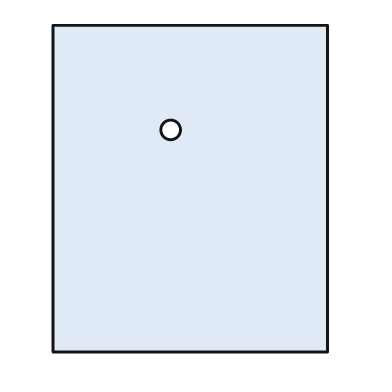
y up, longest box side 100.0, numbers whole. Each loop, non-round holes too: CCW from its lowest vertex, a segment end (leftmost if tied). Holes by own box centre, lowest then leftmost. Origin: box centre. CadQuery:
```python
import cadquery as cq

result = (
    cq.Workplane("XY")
    .moveTo(-42.0, -50.0)
    .lineTo(42.0, -50.0)
    .lineTo(42.0, 50.0)
    .lineTo(-42.0, 50.0)
    .close()
    .moveTo(-6.0, 18.0)
    .circle(3.0)
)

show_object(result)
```